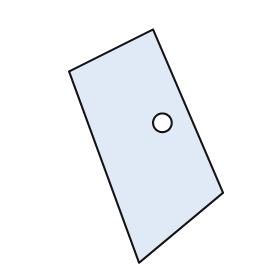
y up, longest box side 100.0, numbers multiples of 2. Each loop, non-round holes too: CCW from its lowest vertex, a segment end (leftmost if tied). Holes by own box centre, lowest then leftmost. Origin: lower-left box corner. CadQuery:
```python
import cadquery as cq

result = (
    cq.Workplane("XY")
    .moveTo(30.0, 0.0)
    .lineTo(66.0, 30.0)
    .lineTo(36.0, 100.0)
    .lineTo(0.0, 82.0)
    .close()
    .moveTo(40.0, 60.0)
    .circle(4.0)
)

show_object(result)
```